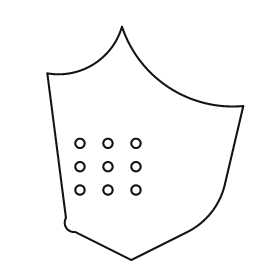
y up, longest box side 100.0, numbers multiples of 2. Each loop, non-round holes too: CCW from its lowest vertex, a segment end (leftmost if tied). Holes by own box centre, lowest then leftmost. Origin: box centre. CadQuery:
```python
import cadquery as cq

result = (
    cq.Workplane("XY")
    .moveTo(-6.0, -50.0)
    .lineTo(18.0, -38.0)
    .threePointArc((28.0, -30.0), (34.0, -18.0))
    .lineTo(42.0, 16.0)
    .threePointArc((10.0, 24.0), (-10.0, 50.0))
    .threePointArc((-22.0, 34.0), (-42.0, 30.0))
    .lineTo(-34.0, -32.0)
    .threePointArc((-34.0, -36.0), (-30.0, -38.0))
    .close()
    .moveTo(-28.0, -20.0)
    .circle(2.0)
    .moveTo(-16.0, -20.0)
    .circle(2.0)
    .moveTo(-4.0, -20.0)
    .circle(2.0)
    .moveTo(-28.0, -10.0)
    .circle(2.0)
    .moveTo(-16.0, -10.0)
    .circle(2.0)
    .moveTo(-4.0, -10.0)
    .circle(2.0)
    .moveTo(-28.0, 0.0)
    .circle(2.0)
    .moveTo(-16.0, 0.0)
    .circle(2.0)
    .moveTo(-4.0, 0.0)
    .circle(2.0)
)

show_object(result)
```